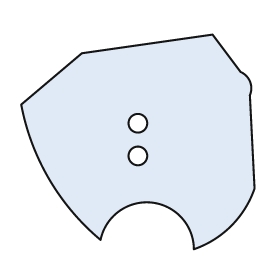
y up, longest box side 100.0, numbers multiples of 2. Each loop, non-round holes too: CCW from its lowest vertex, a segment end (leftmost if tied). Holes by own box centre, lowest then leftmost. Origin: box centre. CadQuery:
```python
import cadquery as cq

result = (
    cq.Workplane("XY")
    .moveTo(24.0, -46.0)
    .threePointArc((40.0, -36.0), (50.0, -20.0))
    .lineTo(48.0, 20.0)
    .threePointArc((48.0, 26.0), (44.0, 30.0))
    .lineTo(32.0, 46.0)
    .lineTo(-24.0, 38.0)
    .lineTo(-50.0, 16.0)
    .threePointArc((-38.0, -16.0), (-16.0, -42.0))
    .threePointArc((6.0, -26.0), (24.0, -46.0))
    .close()
    .moveTo(0.0, -6.0)
    .circle(4.0)
    .moveTo(0.0, 8.0)
    .circle(4.0)
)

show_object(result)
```